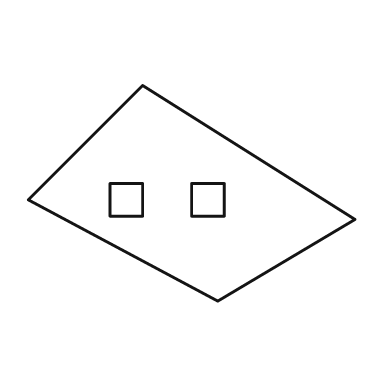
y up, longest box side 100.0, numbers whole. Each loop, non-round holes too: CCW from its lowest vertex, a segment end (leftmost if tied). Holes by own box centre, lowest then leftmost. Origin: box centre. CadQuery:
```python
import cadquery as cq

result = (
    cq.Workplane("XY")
    .moveTo(8.0, -33.0)
    .lineTo(50.0, -8.0)
    .lineTo(-15.0, 33.0)
    .lineTo(-50.0, -2.0)
    .close()
    .moveTo(-25.0, -7.0)
    .lineTo(-15.0, -7.0)
    .lineTo(-15.0, 3.0)
    .lineTo(-25.0, 3.0)
    .close()
    .moveTo(0.0, -7.0)
    .lineTo(10.0, -7.0)
    .lineTo(10.0, 3.0)
    .lineTo(0.0, 3.0)
    .close()
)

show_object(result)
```